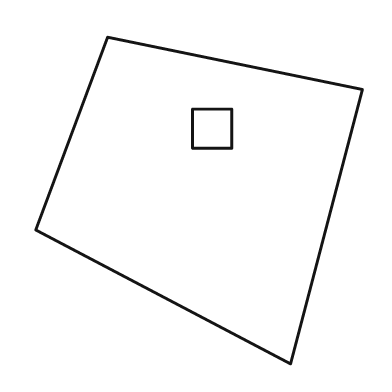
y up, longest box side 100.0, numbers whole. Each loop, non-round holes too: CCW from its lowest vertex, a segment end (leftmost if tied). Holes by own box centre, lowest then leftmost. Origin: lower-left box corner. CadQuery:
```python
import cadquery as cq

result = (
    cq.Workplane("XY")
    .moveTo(78.0, 0.0)
    .lineTo(100.0, 84.0)
    .lineTo(22.0, 100.0)
    .lineTo(0.0, 41.0)
    .close()
    .moveTo(48.0, 66.0)
    .lineTo(60.0, 66.0)
    .lineTo(60.0, 78.0)
    .lineTo(48.0, 78.0)
    .close()
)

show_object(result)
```